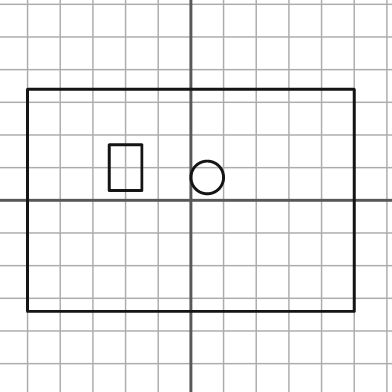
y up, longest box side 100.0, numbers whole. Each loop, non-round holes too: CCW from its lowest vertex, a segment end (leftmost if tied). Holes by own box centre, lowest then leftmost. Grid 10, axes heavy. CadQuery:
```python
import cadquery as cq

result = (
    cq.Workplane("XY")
    .moveTo(-50.0, -34.0)
    .lineTo(50.0, -34.0)
    .lineTo(50.0, 34.0)
    .lineTo(-50.0, 34.0)
    .close()
    .moveTo(5.0, 7.0)
    .circle(5.0)
    .moveTo(-25.0, 3.0)
    .lineTo(-15.0, 3.0)
    .lineTo(-15.0, 17.0)
    .lineTo(-25.0, 17.0)
    .close()
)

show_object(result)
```